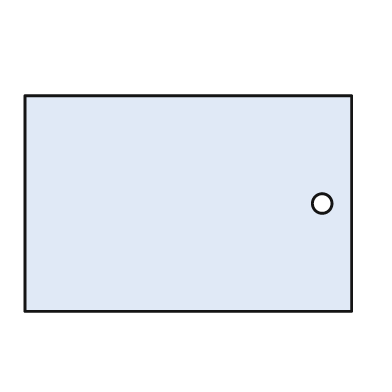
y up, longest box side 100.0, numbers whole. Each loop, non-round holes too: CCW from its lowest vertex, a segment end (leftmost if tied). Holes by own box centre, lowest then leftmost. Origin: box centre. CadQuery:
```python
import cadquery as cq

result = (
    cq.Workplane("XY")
    .moveTo(-50.0, -33.0)
    .lineTo(50.0, -33.0)
    .lineTo(50.0, 33.0)
    .lineTo(-50.0, 33.0)
    .close()
    .moveTo(41.0, 0.0)
    .circle(3.0)
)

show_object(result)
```